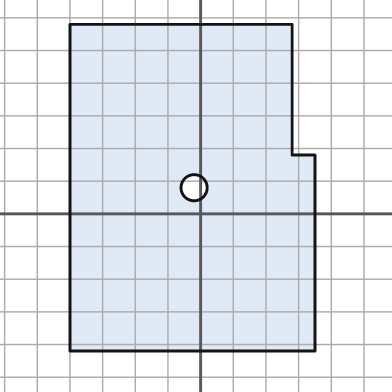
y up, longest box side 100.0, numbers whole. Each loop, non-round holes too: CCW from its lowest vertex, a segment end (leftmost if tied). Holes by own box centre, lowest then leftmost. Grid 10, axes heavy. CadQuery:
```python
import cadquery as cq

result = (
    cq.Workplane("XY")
    .moveTo(-40.0, -42.0)
    .lineTo(35.0, -42.0)
    .lineTo(35.0, 18.0)
    .lineTo(28.0, 18.0)
    .lineTo(28.0, 58.0)
    .lineTo(-40.0, 58.0)
    .close()
    .moveTo(-2.0, 8.0)
    .circle(4.0)
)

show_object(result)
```